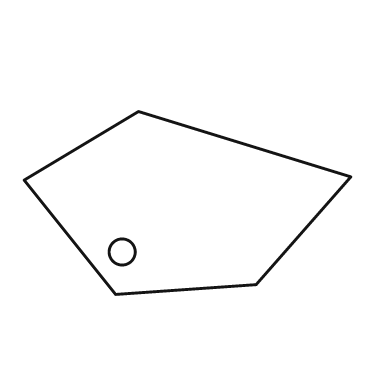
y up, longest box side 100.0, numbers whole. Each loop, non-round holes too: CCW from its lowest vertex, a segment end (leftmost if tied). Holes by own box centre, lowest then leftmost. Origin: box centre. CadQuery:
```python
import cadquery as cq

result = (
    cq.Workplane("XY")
    .moveTo(-22.0, -28.0)
    .lineTo(21.0, -25.0)
    .lineTo(50.0, 8.0)
    .lineTo(-15.0, 28.0)
    .lineTo(-50.0, 7.0)
    .close()
    .moveTo(-20.0, -15.0)
    .circle(4.0)
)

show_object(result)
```